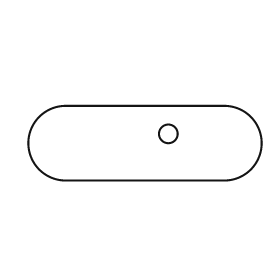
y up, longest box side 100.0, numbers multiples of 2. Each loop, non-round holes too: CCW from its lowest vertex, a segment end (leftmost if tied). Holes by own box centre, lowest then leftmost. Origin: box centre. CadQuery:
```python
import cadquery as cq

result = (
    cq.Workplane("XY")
    .moveTo(-34.0, -16.0)
    .lineTo(34.0, -16.0)
    .threePointArc((50.0, 0.0), (34.0, 16.0))
    .lineTo(-34.0, 16.0)
    .threePointArc((-50.0, 0.0), (-34.0, -16.0))
    .close()
    .moveTo(10.0, 4.0)
    .circle(4.0)
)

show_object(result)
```